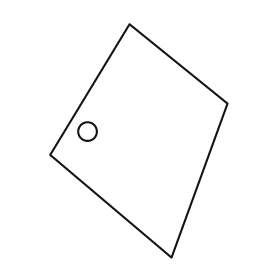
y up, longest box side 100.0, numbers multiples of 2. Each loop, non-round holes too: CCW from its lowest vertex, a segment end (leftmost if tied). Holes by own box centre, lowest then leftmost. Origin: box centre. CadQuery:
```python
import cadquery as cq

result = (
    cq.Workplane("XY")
    .moveTo(14.0, -50.0)
    .lineTo(38.0, 16.0)
    .lineTo(-4.0, 50.0)
    .lineTo(-38.0, -6.0)
    .close()
    .moveTo(-22.0, 4.0)
    .circle(4.0)
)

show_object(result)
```